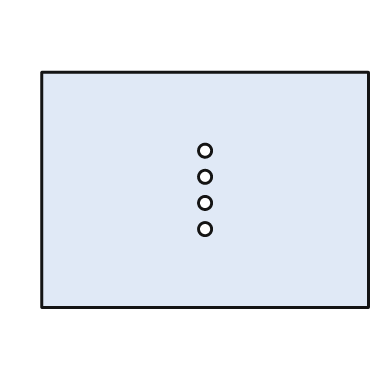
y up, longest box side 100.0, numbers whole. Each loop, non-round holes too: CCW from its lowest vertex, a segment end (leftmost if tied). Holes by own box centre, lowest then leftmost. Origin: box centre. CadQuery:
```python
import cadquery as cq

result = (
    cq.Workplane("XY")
    .moveTo(-50.0, -36.0)
    .lineTo(50.0, -36.0)
    .lineTo(50.0, 36.0)
    .lineTo(-50.0, 36.0)
    .close()
    .moveTo(0.0, -12.0)
    .circle(2.0)
    .moveTo(0.0, -4.0)
    .circle(2.0)
    .moveTo(0.0, 4.0)
    .circle(2.0)
    .moveTo(0.0, 12.0)
    .circle(2.0)
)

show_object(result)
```